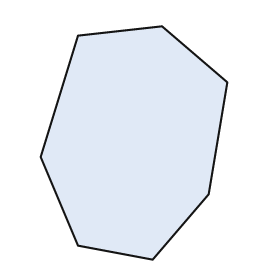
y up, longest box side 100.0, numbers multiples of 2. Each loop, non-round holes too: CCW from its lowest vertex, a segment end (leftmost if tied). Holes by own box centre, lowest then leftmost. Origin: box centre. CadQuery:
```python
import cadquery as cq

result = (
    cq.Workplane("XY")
    .moveTo(8.0, -50.0)
    .lineTo(32.0, -22.0)
    .lineTo(40.0, 26.0)
    .lineTo(12.0, 50.0)
    .lineTo(-24.0, 46.0)
    .lineTo(-40.0, -6.0)
    .lineTo(-24.0, -44.0)
    .close()
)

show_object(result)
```